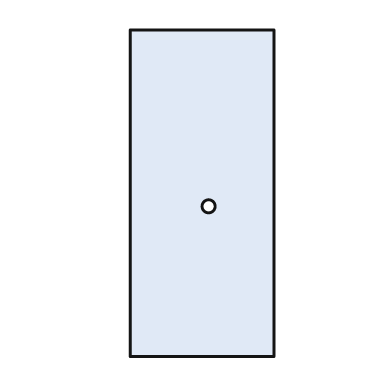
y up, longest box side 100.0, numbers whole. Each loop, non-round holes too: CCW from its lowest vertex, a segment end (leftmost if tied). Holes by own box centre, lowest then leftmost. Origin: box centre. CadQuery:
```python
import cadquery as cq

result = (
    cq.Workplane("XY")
    .moveTo(-22.0, -50.0)
    .lineTo(22.0, -50.0)
    .lineTo(22.0, 50.0)
    .lineTo(-22.0, 50.0)
    .close()
    .moveTo(2.0, -4.0)
    .circle(2.0)
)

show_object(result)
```